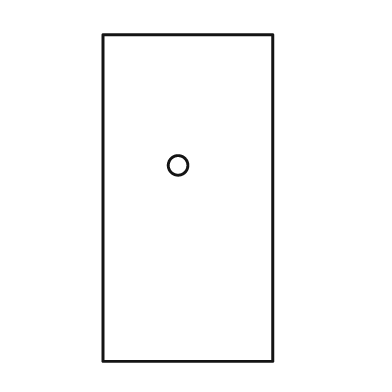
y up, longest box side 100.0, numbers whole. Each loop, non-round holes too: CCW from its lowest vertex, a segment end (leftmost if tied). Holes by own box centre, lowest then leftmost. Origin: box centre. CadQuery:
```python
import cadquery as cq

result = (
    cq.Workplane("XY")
    .moveTo(-26.0, -50.0)
    .lineTo(26.0, -50.0)
    .lineTo(26.0, 50.0)
    .lineTo(-26.0, 50.0)
    .close()
    .moveTo(-3.0, 10.0)
    .circle(3.0)
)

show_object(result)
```